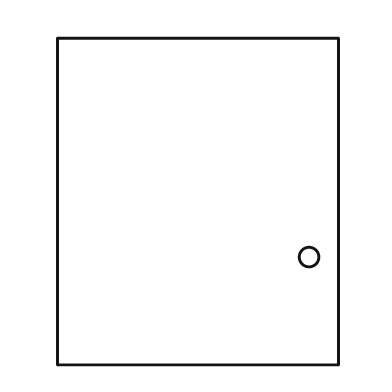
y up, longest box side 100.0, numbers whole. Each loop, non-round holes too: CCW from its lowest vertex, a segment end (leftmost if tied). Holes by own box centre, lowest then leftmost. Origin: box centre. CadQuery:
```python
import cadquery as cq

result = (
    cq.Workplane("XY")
    .moveTo(-43.0, -50.0)
    .lineTo(43.0, -50.0)
    .lineTo(43.0, 50.0)
    .lineTo(-43.0, 50.0)
    .close()
    .moveTo(34.0, -17.0)
    .circle(3.0)
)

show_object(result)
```